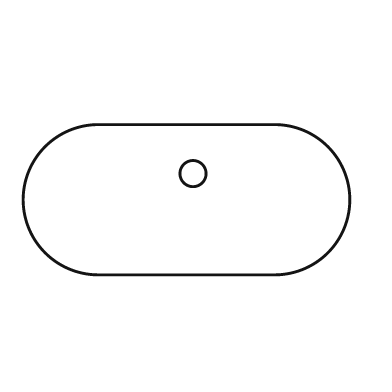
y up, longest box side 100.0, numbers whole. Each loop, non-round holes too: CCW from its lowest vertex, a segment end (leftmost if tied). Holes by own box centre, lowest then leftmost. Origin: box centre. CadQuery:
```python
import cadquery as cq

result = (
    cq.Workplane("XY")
    .moveTo(-27.0, -23.0)
    .lineTo(27.0, -23.0)
    .threePointArc((50.0, 0.0), (27.0, 23.0))
    .lineTo(-27.0, 23.0)
    .threePointArc((-50.0, 0.0), (-27.0, -23.0))
    .close()
    .moveTo(2.0, 8.0)
    .circle(4.0)
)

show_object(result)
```